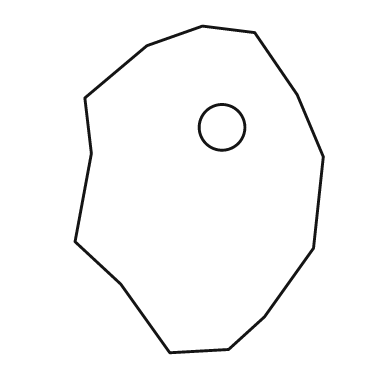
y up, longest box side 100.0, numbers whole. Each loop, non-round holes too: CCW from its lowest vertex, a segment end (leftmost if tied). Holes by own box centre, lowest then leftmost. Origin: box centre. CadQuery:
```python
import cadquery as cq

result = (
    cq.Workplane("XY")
    .moveTo(-9.0, -50.0)
    .lineTo(9.0, -49.0)
    .lineTo(20.0, -39.0)
    .lineTo(35.0, -18.0)
    .lineTo(38.0, 10.0)
    .lineTo(30.0, 29.0)
    .lineTo(17.0, 48.0)
    .lineTo(1.0, 50.0)
    .lineTo(-16.0, 44.0)
    .lineTo(-35.0, 28.0)
    .lineTo(-33.0, 11.0)
    .lineTo(-38.0, -16.0)
    .lineTo(-24.0, -29.0)
    .close()
    .moveTo(7.0, 19.0)
    .circle(7.0)
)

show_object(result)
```